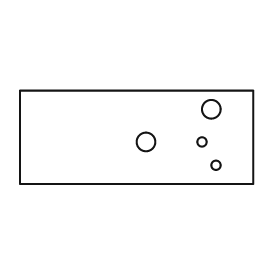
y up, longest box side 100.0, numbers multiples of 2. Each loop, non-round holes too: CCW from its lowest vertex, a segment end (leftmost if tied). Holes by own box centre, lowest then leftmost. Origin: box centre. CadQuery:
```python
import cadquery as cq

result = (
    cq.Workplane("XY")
    .moveTo(-50.0, -20.0)
    .lineTo(50.0, -20.0)
    .lineTo(50.0, 20.0)
    .lineTo(-50.0, 20.0)
    .close()
    .moveTo(34.0, -12.0)
    .circle(2.0)
    .moveTo(4.0, -2.0)
    .circle(4.0)
    .moveTo(28.0, -2.0)
    .circle(2.0)
    .moveTo(32.0, 12.0)
    .circle(4.0)
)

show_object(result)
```